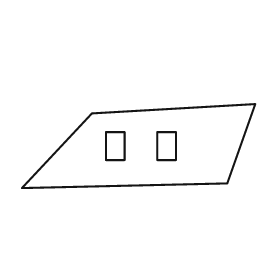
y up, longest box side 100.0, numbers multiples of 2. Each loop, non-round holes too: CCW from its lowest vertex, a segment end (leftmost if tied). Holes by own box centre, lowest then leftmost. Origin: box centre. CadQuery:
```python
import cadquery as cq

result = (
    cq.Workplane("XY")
    .moveTo(-50.0, -18.0)
    .lineTo(38.0, -16.0)
    .lineTo(50.0, 18.0)
    .lineTo(-20.0, 14.0)
    .close()
    .moveTo(-14.0, -6.0)
    .lineTo(-6.0, -6.0)
    .lineTo(-6.0, 6.0)
    .lineTo(-14.0, 6.0)
    .close()
    .moveTo(8.0, -6.0)
    .lineTo(16.0, -6.0)
    .lineTo(16.0, 6.0)
    .lineTo(8.0, 6.0)
    .close()
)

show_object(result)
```